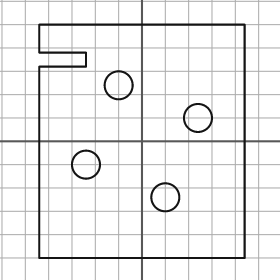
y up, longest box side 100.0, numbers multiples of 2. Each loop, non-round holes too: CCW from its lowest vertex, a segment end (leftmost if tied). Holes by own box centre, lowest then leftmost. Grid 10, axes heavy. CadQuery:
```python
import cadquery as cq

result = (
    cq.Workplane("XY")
    .moveTo(-44.0, -50.0)
    .lineTo(44.0, -50.0)
    .lineTo(44.0, 50.0)
    .lineTo(-44.0, 50.0)
    .lineTo(-44.0, 38.0)
    .lineTo(-24.0, 38.0)
    .lineTo(-24.0, 32.0)
    .lineTo(-44.0, 32.0)
    .close()
    .moveTo(10.0, -24.0)
    .circle(6.0)
    .moveTo(-24.0, -10.0)
    .circle(6.0)
    .moveTo(24.0, 10.0)
    .circle(6.0)
    .moveTo(-10.0, 24.0)
    .circle(6.0)
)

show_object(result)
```